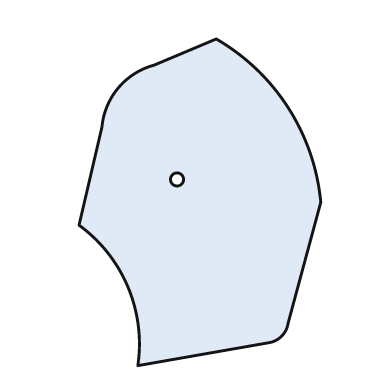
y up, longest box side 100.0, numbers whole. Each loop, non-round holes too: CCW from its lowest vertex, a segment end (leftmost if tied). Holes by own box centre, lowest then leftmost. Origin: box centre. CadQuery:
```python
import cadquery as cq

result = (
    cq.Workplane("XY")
    .moveTo(-19.0, -50.0)
    .lineTo(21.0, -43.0)
    .threePointArc((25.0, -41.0), (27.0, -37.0))
    .lineTo(37.0, 0.0)
    .threePointArc((27.0, 29.0), (5.0, 50.0))
    .lineTo(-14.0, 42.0)
    .threePointArc((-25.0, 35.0), (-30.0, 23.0))
    .lineTo(-37.0, -7.0)
    .threePointArc((-22.0, -26.0), (-19.0, -50.0))
    .close()
    .moveTo(-7.0, 7.0)
    .circle(2.0)
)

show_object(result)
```